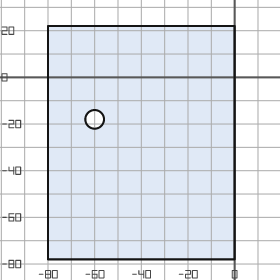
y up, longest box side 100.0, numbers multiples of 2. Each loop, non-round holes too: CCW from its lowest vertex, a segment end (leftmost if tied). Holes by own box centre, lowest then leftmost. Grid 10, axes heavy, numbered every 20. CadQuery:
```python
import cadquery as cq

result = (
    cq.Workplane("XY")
    .moveTo(-80.0, -78.0)
    .lineTo(0.0, -78.0)
    .lineTo(0.0, 22.0)
    .lineTo(-80.0, 22.0)
    .close()
    .moveTo(-60.0, -18.0)
    .circle(4.0)
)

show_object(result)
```